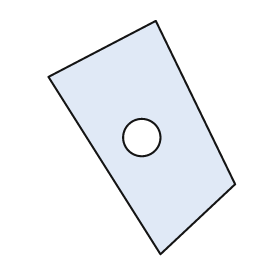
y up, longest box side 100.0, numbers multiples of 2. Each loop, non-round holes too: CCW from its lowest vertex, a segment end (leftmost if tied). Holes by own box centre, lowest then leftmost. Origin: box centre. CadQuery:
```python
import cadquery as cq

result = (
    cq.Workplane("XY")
    .moveTo(8.0, -50.0)
    .lineTo(40.0, -20.0)
    .lineTo(6.0, 50.0)
    .lineTo(-40.0, 26.0)
    .close()
    .moveTo(0.0, 0.0)
    .circle(8.0)
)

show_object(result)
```